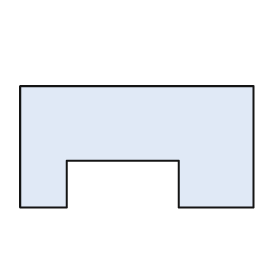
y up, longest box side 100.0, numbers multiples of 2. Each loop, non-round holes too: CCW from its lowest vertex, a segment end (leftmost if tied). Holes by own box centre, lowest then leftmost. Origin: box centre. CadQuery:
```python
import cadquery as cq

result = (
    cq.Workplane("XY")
    .moveTo(-50.0, -26.0)
    .lineTo(-30.0, -26.0)
    .lineTo(-30.0, -6.0)
    .lineTo(18.0, -6.0)
    .lineTo(18.0, -26.0)
    .lineTo(50.0, -26.0)
    .lineTo(50.0, 26.0)
    .lineTo(-50.0, 26.0)
    .close()
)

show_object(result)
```